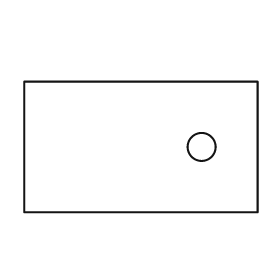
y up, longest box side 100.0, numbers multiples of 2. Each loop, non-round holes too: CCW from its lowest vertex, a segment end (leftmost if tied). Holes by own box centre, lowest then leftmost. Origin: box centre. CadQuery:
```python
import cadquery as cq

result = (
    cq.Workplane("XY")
    .moveTo(-50.0, -28.0)
    .lineTo(50.0, -28.0)
    .lineTo(50.0, 28.0)
    .lineTo(-50.0, 28.0)
    .close()
    .moveTo(26.0, 0.0)
    .circle(6.0)
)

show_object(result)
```